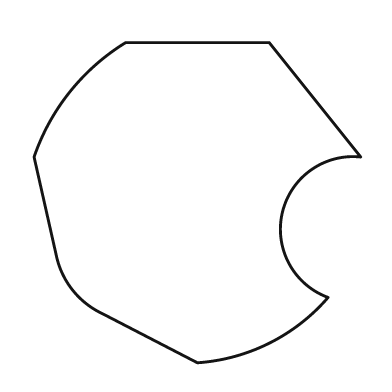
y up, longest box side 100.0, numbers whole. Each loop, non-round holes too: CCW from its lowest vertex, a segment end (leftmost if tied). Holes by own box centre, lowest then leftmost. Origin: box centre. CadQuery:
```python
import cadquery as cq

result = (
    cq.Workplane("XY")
    .moveTo(0.0, -49.0)
    .threePointArc((22.0, -43.0), (40.0, -29.0))
    .threePointArc((26.0, -3.0), (50.0, 14.0))
    .lineTo(22.0, 49.0)
    .lineTo(-22.0, 49.0)
    .threePointArc((-39.0, 34.0), (-50.0, 14.0))
    .lineTo(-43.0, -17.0)
    .threePointArc((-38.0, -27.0), (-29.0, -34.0))
    .close()
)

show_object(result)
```